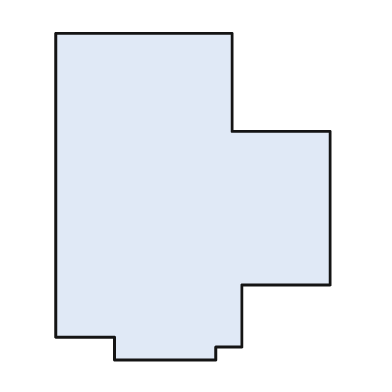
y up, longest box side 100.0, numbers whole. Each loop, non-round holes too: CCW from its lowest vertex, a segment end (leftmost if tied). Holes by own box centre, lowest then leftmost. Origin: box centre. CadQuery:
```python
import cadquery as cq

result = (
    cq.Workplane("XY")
    .moveTo(-24.0, -50.0)
    .lineTo(7.0, -50.0)
    .lineTo(7.0, -46.0)
    .lineTo(15.0, -46.0)
    .lineTo(15.0, -27.0)
    .lineTo(42.0, -27.0)
    .lineTo(42.0, 20.0)
    .lineTo(12.0, 20.0)
    .lineTo(12.0, 50.0)
    .lineTo(-42.0, 50.0)
    .lineTo(-42.0, -43.0)
    .lineTo(-24.0, -43.0)
    .close()
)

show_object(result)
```